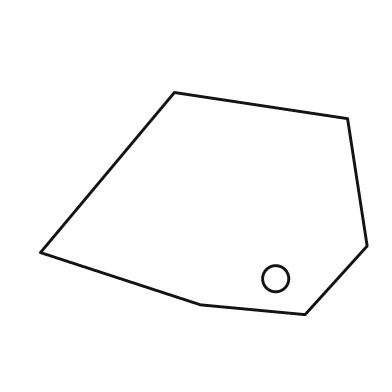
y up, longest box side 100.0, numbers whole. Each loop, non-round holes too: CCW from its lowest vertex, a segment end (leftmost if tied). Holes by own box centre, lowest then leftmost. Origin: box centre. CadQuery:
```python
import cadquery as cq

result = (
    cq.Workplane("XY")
    .moveTo(31.0, -34.0)
    .lineTo(50.0, -13.0)
    .lineTo(44.0, 26.0)
    .lineTo(-9.0, 34.0)
    .lineTo(-50.0, -15.0)
    .lineTo(-1.0, -31.0)
    .close()
    .moveTo(22.0, -23.0)
    .circle(4.0)
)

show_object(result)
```